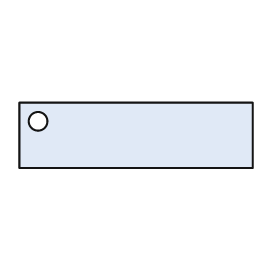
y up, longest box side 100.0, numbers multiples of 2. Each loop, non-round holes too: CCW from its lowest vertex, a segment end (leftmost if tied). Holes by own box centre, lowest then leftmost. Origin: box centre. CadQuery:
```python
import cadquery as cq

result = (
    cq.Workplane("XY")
    .moveTo(-50.0, -14.0)
    .lineTo(50.0, -14.0)
    .lineTo(50.0, 14.0)
    .lineTo(-50.0, 14.0)
    .close()
    .moveTo(-42.0, 6.0)
    .circle(4.0)
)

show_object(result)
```